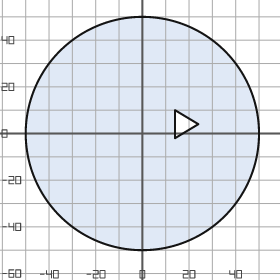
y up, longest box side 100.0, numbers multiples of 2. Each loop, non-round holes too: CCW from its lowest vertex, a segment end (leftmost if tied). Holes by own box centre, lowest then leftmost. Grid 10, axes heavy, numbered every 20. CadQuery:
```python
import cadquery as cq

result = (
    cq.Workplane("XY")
    .moveTo(0.0, 0.0)
    .circle(50.0)
    .moveTo(14.0, -2.0)
    .lineTo(24.0, 4.0)
    .lineTo(14.0, 10.0)
    .close()
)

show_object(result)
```